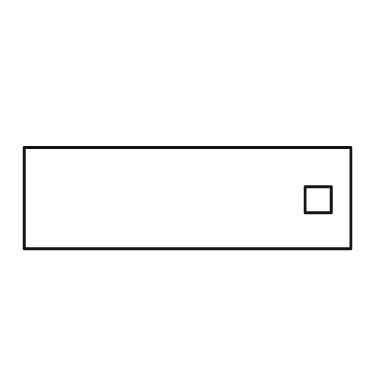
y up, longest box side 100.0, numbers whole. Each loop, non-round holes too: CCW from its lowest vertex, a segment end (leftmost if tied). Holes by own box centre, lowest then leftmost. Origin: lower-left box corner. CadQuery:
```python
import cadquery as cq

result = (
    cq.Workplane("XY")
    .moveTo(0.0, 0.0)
    .lineTo(100.0, 0.0)
    .lineTo(100.0, 31.0)
    .lineTo(0.0, 31.0)
    .close()
    .moveTo(86.0, 11.0)
    .lineTo(94.0, 11.0)
    .lineTo(94.0, 19.0)
    .lineTo(86.0, 19.0)
    .close()
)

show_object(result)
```